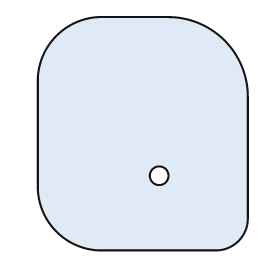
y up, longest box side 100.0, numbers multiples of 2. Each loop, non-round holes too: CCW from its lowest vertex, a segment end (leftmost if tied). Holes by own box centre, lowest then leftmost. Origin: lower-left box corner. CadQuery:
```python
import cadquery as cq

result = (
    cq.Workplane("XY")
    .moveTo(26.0, 0.0)
    .lineTo(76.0, 0.0)
    .threePointArc((86.0, 4.0), (90.0, 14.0))
    .lineTo(90.0, 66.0)
    .threePointArc((80.0, 90.0), (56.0, 100.0))
    .lineTo(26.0, 100.0)
    .threePointArc((8.0, 92.0), (0.0, 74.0))
    .lineTo(0.0, 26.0)
    .threePointArc((8.0, 8.0), (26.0, 0.0))
    .close()
    .moveTo(52.0, 32.0)
    .circle(4.0)
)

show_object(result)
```